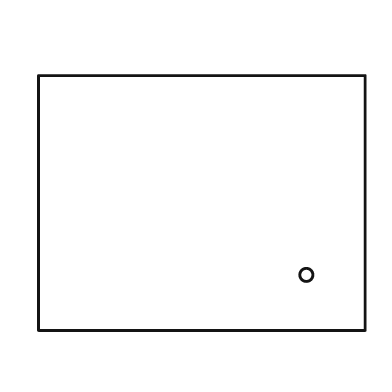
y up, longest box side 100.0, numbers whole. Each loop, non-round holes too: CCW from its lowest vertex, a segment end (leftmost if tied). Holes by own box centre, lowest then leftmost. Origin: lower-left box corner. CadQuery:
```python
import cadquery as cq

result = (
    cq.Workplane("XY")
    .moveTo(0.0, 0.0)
    .lineTo(100.0, 0.0)
    .lineTo(100.0, 78.0)
    .lineTo(0.0, 78.0)
    .close()
    .moveTo(82.0, 17.0)
    .circle(2.0)
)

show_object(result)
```